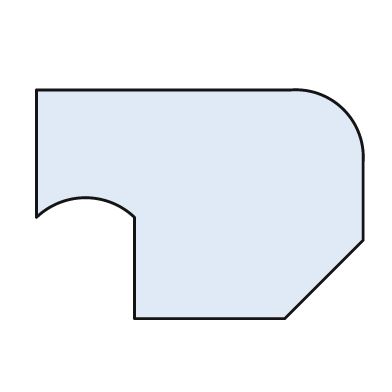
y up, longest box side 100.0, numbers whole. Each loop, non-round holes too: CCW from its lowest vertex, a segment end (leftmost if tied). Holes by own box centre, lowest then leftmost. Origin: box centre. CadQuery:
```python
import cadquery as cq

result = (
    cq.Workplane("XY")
    .moveTo(-20.0, -35.0)
    .lineTo(26.0, -35.0)
    .lineTo(50.0, -11.0)
    .lineTo(50.0, 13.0)
    .threePointArc((44.0, 29.0), (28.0, 35.0))
    .lineTo(-50.0, 35.0)
    .lineTo(-50.0, -4.0)
    .threePointArc((-35.0, 2.0), (-20.0, -4.0))
    .close()
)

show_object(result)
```